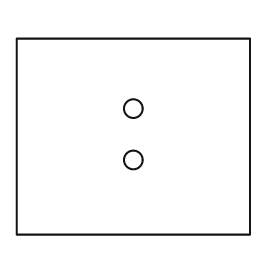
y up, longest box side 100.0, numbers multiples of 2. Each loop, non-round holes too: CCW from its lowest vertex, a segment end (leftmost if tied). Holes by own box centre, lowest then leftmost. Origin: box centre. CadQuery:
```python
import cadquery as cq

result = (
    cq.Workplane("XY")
    .moveTo(-50.0, -42.0)
    .lineTo(50.0, -42.0)
    .lineTo(50.0, 42.0)
    .lineTo(-50.0, 42.0)
    .close()
    .moveTo(0.0, -10.0)
    .circle(4.0)
    .moveTo(0.0, 12.0)
    .circle(4.0)
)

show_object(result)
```